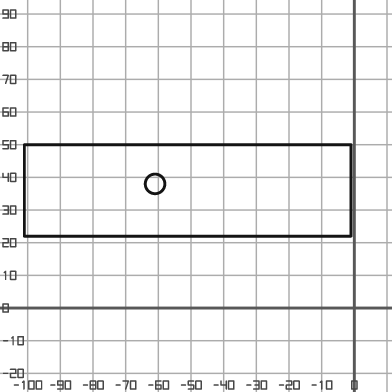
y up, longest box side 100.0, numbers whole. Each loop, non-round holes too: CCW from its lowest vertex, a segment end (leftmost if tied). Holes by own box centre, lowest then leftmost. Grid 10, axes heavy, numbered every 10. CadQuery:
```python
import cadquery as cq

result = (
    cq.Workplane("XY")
    .moveTo(-101.0, 22.0)
    .lineTo(-1.0, 22.0)
    .lineTo(-1.0, 50.0)
    .lineTo(-101.0, 50.0)
    .close()
    .moveTo(-61.0, 38.0)
    .circle(3.0)
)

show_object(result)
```